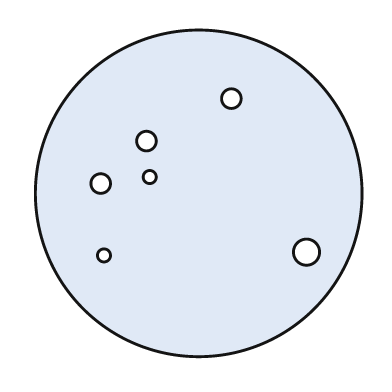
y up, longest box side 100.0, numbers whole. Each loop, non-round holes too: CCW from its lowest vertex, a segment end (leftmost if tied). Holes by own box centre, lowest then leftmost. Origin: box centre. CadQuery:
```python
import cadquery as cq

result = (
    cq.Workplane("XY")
    .moveTo(0.0, 0.0)
    .circle(50.0)
    .moveTo(-29.0, -19.0)
    .circle(2.0)
    .moveTo(33.0, -18.0)
    .circle(4.0)
    .moveTo(-30.0, 3.0)
    .circle(3.0)
    .moveTo(-15.0, 5.0)
    .circle(2.0)
    .moveTo(-16.0, 16.0)
    .circle(3.0)
    .moveTo(10.0, 29.0)
    .circle(3.0)
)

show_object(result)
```